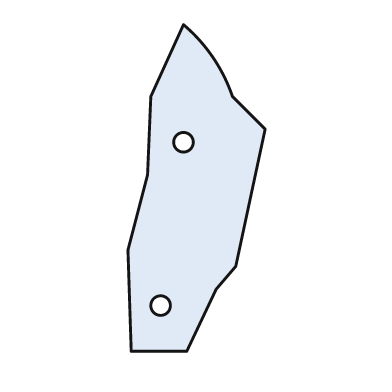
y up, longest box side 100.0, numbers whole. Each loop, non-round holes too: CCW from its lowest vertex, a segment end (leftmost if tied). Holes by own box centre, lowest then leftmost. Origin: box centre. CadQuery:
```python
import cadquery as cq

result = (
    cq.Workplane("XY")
    .moveTo(-20.0, -50.0)
    .lineTo(-3.0, -50.0)
    .lineTo(6.0, -31.0)
    .lineTo(12.0, -24.0)
    .lineTo(21.0, 18.0)
    .lineTo(11.0, 28.0)
    .threePointArc((5.0, 40.0), (-4.0, 50.0))
    .lineTo(-14.0, 28.0)
    .lineTo(-15.0, 4.0)
    .lineTo(-21.0, -19.0)
    .close()
    .moveTo(-11.0, -36.0)
    .circle(3.0)
    .moveTo(-4.0, 14.0)
    .circle(3.0)
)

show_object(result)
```